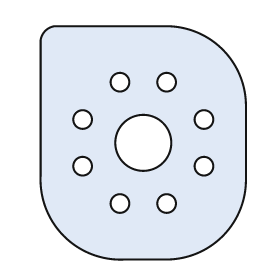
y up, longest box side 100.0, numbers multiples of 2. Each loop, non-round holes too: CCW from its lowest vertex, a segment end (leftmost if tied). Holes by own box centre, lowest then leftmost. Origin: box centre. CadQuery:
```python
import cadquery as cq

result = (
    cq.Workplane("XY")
    .moveTo(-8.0, -50.0)
    .lineTo(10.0, -50.0)
    .threePointArc((34.0, -40.0), (44.0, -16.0))
    .lineTo(44.0, 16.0)
    .threePointArc((34.0, 40.0), (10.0, 50.0))
    .lineTo(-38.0, 50.0)
    .threePointArc((-42.0, 48.0), (-44.0, 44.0))
    .lineTo(-44.0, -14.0)
    .threePointArc((-34.0, -40.0), (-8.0, -50.0))
    .close()
    .moveTo(-10.0, -26.0)
    .circle(4.0)
    .moveTo(10.0, -26.0)
    .circle(4.0)
    .moveTo(-26.0, -10.0)
    .circle(4.0)
    .moveTo(26.0, -10.0)
    .circle(4.0)
    .moveTo(0.0, 0.0)
    .circle(12.0)
    .moveTo(-26.0, 10.0)
    .circle(4.0)
    .moveTo(26.0, 10.0)
    .circle(4.0)
    .moveTo(-10.0, 26.0)
    .circle(4.0)
    .moveTo(10.0, 26.0)
    .circle(4.0)
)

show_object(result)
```